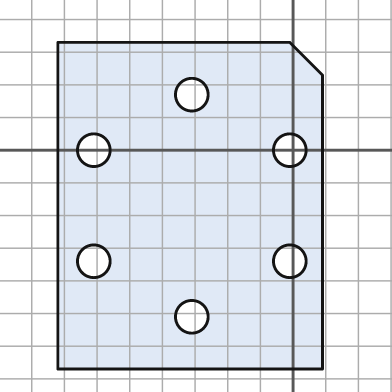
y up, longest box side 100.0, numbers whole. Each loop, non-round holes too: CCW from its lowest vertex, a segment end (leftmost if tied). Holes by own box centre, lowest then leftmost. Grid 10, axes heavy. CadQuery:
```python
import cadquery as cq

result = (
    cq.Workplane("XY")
    .moveTo(-72.0, -67.0)
    .lineTo(9.0, -67.0)
    .lineTo(9.0, 23.0)
    .lineTo(-1.0, 33.0)
    .lineTo(-72.0, 33.0)
    .close()
    .moveTo(-31.0, -51.0)
    .circle(5.0)
    .moveTo(-61.0, -34.0)
    .circle(5.0)
    .moveTo(-1.0, -34.0)
    .circle(5.0)
    .moveTo(-61.0, 0.0)
    .circle(5.0)
    .moveTo(-1.0, 0.0)
    .circle(5.0)
    .moveTo(-31.0, 17.0)
    .circle(5.0)
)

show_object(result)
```